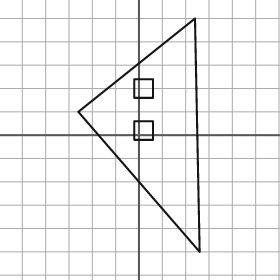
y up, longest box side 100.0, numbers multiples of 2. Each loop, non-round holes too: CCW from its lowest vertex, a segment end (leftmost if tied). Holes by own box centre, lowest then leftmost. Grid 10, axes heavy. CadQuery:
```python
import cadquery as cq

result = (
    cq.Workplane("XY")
    .moveTo(26.0, -50.0)
    .lineTo(24.0, 50.0)
    .lineTo(-26.0, 10.0)
    .close()
    .moveTo(-2.0, -2.0)
    .lineTo(6.0, -2.0)
    .lineTo(6.0, 6.0)
    .lineTo(-2.0, 6.0)
    .close()
    .moveTo(-2.0, 16.0)
    .lineTo(6.0, 16.0)
    .lineTo(6.0, 24.0)
    .lineTo(-2.0, 24.0)
    .close()
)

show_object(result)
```